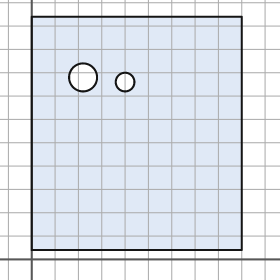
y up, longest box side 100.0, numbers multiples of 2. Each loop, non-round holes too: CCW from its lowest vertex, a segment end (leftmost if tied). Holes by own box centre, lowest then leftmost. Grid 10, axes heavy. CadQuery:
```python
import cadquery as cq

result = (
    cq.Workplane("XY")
    .moveTo(0.0, 4.0)
    .lineTo(90.0, 4.0)
    .lineTo(90.0, 104.0)
    .lineTo(0.0, 104.0)
    .close()
    .moveTo(40.0, 76.0)
    .circle(4.0)
    .moveTo(22.0, 78.0)
    .circle(6.0)
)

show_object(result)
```